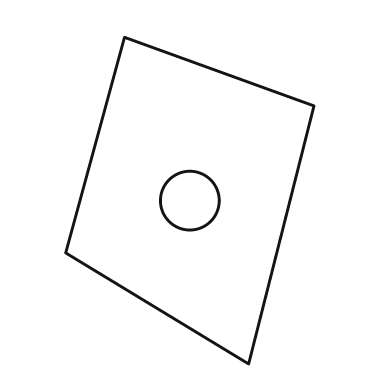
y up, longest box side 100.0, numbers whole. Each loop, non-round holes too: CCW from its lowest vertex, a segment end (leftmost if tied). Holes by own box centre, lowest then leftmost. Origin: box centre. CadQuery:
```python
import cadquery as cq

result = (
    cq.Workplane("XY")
    .moveTo(18.0, -50.0)
    .lineTo(38.0, 29.0)
    .lineTo(-20.0, 50.0)
    .lineTo(-38.0, -16.0)
    .close()
    .moveTo(0.0, 0.0)
    .circle(9.0)
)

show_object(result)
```